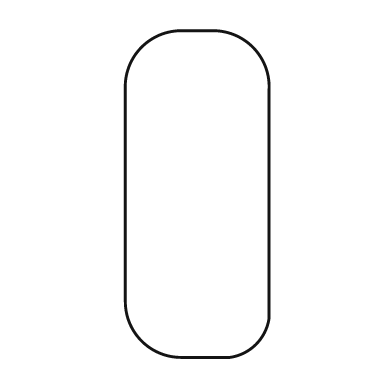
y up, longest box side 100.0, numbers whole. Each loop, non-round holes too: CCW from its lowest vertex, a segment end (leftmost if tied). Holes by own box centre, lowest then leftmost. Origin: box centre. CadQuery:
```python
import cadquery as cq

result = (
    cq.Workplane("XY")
    .moveTo(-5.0, -50.0)
    .lineTo(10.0, -50.0)
    .threePointArc((18.0, -46.0), (22.0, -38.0))
    .lineTo(22.0, 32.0)
    .threePointArc((17.0, 45.0), (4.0, 50.0))
    .lineTo(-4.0, 50.0)
    .threePointArc((-17.0, 45.0), (-22.0, 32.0))
    .lineTo(-22.0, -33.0)
    .threePointArc((-17.0, -45.0), (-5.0, -50.0))
    .close()
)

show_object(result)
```